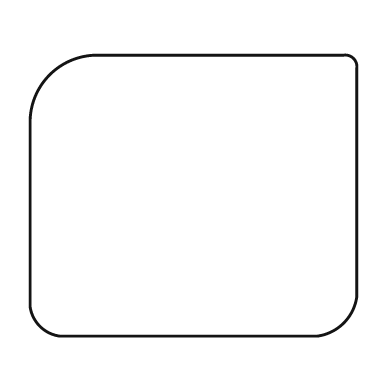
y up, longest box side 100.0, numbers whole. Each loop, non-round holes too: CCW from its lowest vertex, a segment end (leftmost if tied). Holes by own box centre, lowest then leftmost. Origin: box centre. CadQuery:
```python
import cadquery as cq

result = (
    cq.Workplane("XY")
    .moveTo(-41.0, -43.0)
    .lineTo(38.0, -43.0)
    .threePointArc((46.0, -39.0), (50.0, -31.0))
    .lineTo(50.0, 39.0)
    .threePointArc((49.0, 42.0), (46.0, 43.0))
    .lineTo(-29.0, 43.0)
    .threePointArc((-44.0, 37.0), (-50.0, 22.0))
    .lineTo(-50.0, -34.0)
    .threePointArc((-47.0, -40.0), (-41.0, -43.0))
    .close()
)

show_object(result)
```